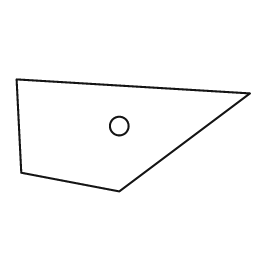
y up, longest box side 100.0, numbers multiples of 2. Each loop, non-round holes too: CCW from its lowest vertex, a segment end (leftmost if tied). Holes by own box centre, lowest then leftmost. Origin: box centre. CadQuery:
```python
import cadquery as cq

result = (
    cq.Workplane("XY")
    .moveTo(-6.0, -24.0)
    .lineTo(50.0, 18.0)
    .lineTo(-50.0, 24.0)
    .lineTo(-48.0, -16.0)
    .close()
    .moveTo(-6.0, 4.0)
    .circle(4.0)
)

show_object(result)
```